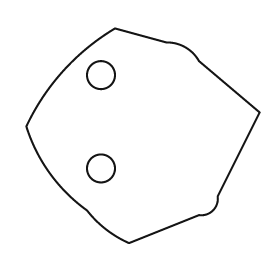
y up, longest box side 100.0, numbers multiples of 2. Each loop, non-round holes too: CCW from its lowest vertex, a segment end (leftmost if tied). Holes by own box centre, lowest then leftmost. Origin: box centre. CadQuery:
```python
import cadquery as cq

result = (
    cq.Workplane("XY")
    .moveTo(-6.0, -46.0)
    .lineTo(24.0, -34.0)
    .threePointArc((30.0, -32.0), (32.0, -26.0))
    .lineTo(50.0, 10.0)
    .lineTo(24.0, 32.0)
    .threePointArc((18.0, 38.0), (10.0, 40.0))
    .lineTo(-12.0, 46.0)
    .threePointArc((-34.0, 28.0), (-50.0, 4.0))
    .threePointArc((-40.0, -16.0), (-24.0, -32.0))
    .threePointArc((-16.0, -40.0), (-6.0, -46.0))
    .close()
    .moveTo(-18.0, -14.0)
    .circle(6.0)
    .moveTo(-18.0, 26.0)
    .circle(6.0)
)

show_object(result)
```